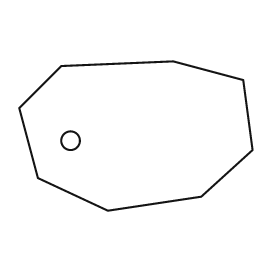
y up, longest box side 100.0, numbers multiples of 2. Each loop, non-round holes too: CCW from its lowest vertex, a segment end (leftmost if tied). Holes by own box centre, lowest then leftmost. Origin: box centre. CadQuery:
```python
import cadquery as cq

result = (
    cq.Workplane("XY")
    .moveTo(-12.0, -32.0)
    .lineTo(28.0, -26.0)
    .lineTo(50.0, -6.0)
    .lineTo(46.0, 24.0)
    .lineTo(16.0, 32.0)
    .lineTo(-32.0, 30.0)
    .lineTo(-50.0, 12.0)
    .lineTo(-42.0, -18.0)
    .close()
    .moveTo(-28.0, -2.0)
    .circle(4.0)
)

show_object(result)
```